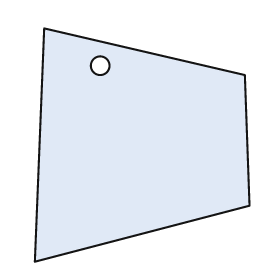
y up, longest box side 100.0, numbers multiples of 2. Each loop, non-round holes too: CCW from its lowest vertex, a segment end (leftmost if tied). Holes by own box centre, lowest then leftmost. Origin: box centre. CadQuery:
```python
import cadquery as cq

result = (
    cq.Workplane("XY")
    .moveTo(-46.0, -50.0)
    .lineTo(46.0, -26.0)
    .lineTo(44.0, 30.0)
    .lineTo(-42.0, 50.0)
    .close()
    .moveTo(-18.0, 34.0)
    .circle(4.0)
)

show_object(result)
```